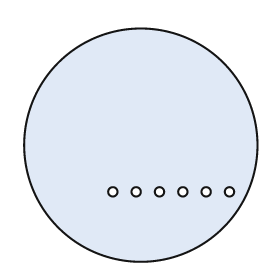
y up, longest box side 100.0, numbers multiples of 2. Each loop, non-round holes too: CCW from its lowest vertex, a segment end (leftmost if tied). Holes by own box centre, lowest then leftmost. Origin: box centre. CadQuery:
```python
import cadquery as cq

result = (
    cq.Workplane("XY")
    .moveTo(0.0, 0.0)
    .circle(50.0)
    .moveTo(-12.0, -20.0)
    .circle(2.0)
    .moveTo(-2.0, -20.0)
    .circle(2.0)
    .moveTo(8.0, -20.0)
    .circle(2.0)
    .moveTo(18.0, -20.0)
    .circle(2.0)
    .moveTo(28.0, -20.0)
    .circle(2.0)
    .moveTo(38.0, -20.0)
    .circle(2.0)
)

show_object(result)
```